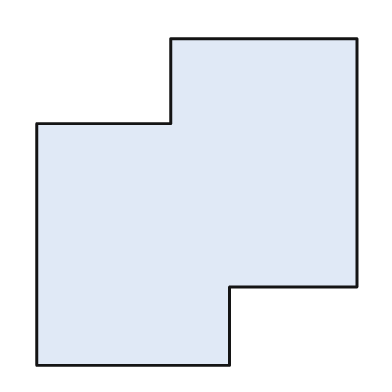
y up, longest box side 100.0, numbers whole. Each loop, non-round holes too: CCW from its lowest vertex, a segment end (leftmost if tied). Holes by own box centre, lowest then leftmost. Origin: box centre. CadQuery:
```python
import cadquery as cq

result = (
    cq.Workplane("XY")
    .moveTo(-49.0, -50.0)
    .lineTo(10.0, -50.0)
    .lineTo(10.0, -26.0)
    .lineTo(49.0, -26.0)
    .lineTo(49.0, 50.0)
    .lineTo(-8.0, 50.0)
    .lineTo(-8.0, 24.0)
    .lineTo(-49.0, 24.0)
    .close()
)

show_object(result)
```